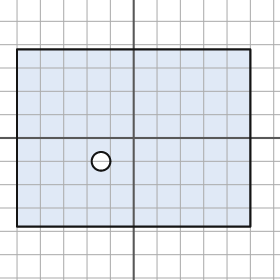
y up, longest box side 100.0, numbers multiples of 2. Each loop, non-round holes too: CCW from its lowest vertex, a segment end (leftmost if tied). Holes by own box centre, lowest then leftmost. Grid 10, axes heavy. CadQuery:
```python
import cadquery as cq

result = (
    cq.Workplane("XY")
    .moveTo(-50.0, -38.0)
    .lineTo(50.0, -38.0)
    .lineTo(50.0, 38.0)
    .lineTo(-50.0, 38.0)
    .close()
    .moveTo(-14.0, -10.0)
    .circle(4.0)
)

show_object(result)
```